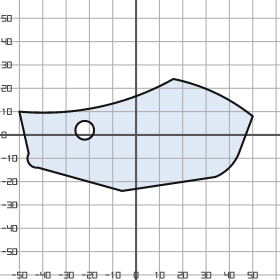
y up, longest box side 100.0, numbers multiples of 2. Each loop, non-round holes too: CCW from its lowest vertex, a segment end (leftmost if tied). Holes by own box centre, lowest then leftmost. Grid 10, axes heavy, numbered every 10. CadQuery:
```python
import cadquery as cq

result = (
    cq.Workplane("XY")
    .moveTo(-6.0, -24.0)
    .lineTo(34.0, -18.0)
    .threePointArc((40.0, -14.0), (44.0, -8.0))
    .lineTo(50.0, 8.0)
    .threePointArc((34.0, 18.0), (16.0, 24.0))
    .threePointArc((-16.0, 12.0), (-50.0, 10.0))
    .lineTo(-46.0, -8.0)
    .threePointArc((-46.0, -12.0), (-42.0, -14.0))
    .close()
    .moveTo(-22.0, 2.0)
    .circle(4.0)
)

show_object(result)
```